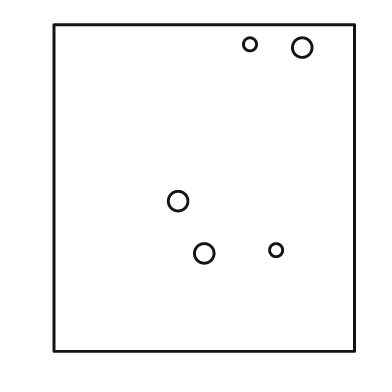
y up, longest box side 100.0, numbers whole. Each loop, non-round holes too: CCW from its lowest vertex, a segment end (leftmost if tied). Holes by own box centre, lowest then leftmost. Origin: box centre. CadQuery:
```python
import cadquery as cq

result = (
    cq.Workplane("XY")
    .moveTo(-46.0, -50.0)
    .lineTo(46.0, -50.0)
    .lineTo(46.0, 50.0)
    .lineTo(-46.0, 50.0)
    .close()
    .moveTo(0.0, -20.0)
    .circle(3.0)
    .moveTo(22.0, -19.0)
    .circle(2.0)
    .moveTo(-8.0, -4.0)
    .circle(3.0)
    .moveTo(30.0, 43.0)
    .circle(3.0)
    .moveTo(14.0, 44.0)
    .circle(2.0)
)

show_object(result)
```